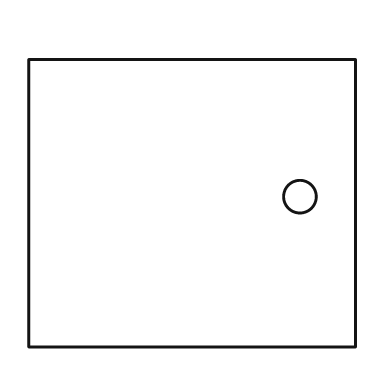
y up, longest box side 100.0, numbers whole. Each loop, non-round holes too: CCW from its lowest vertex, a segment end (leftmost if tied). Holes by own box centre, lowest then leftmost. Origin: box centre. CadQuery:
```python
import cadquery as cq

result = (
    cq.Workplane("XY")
    .moveTo(-50.0, -44.0)
    .lineTo(50.0, -44.0)
    .lineTo(50.0, 44.0)
    .lineTo(-50.0, 44.0)
    .close()
    .moveTo(33.0, 2.0)
    .circle(5.0)
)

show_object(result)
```